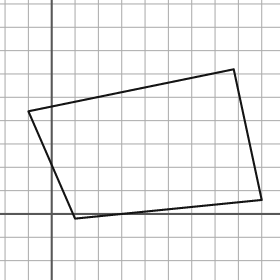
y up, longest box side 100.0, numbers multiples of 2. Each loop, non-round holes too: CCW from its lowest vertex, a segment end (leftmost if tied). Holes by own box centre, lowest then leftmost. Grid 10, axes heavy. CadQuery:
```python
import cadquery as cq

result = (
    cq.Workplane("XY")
    .moveTo(10.0, -2.0)
    .lineTo(90.0, 6.0)
    .lineTo(78.0, 62.0)
    .lineTo(-10.0, 44.0)
    .close()
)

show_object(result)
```